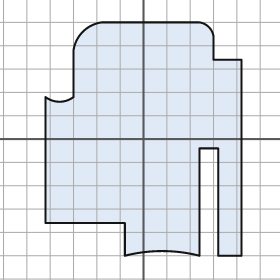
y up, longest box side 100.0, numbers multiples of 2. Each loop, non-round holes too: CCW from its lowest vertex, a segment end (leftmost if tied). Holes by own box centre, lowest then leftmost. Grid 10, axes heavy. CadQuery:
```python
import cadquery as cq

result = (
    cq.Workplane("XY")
    .moveTo(-8.0, -50.0)
    .threePointArc((8.0, -48.0), (24.0, -50.0))
    .lineTo(24.0, -4.0)
    .lineTo(32.0, -4.0)
    .lineTo(32.0, -50.0)
    .lineTo(42.0, -50.0)
    .lineTo(42.0, 34.0)
    .lineTo(30.0, 34.0)
    .lineTo(30.0, 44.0)
    .threePointArc((28.0, 48.0), (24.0, 50.0))
    .lineTo(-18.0, 50.0)
    .threePointArc((-26.0, 46.0), (-30.0, 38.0))
    .lineTo(-30.0, 18.0)
    .threePointArc((-36.0, 16.0), (-42.0, 18.0))
    .lineTo(-42.0, -36.0)
    .lineTo(-8.0, -36.0)
    .close()
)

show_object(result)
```